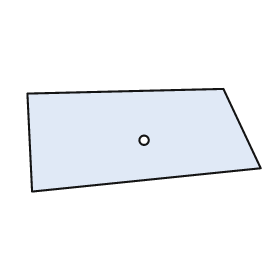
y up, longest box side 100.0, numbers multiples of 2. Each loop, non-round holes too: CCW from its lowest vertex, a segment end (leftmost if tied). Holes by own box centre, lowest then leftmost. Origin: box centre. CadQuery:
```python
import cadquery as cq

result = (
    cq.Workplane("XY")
    .moveTo(-48.0, -22.0)
    .lineTo(50.0, -12.0)
    .lineTo(34.0, 22.0)
    .lineTo(-50.0, 20.0)
    .close()
    .moveTo(0.0, 0.0)
    .circle(2.0)
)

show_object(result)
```